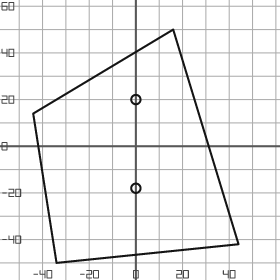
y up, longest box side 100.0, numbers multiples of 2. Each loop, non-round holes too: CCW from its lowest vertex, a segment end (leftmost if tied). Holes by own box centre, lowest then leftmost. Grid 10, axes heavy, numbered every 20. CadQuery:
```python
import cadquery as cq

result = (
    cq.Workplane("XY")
    .moveTo(-34.0, -50.0)
    .lineTo(44.0, -42.0)
    .lineTo(16.0, 50.0)
    .lineTo(-44.0, 14.0)
    .close()
    .moveTo(0.0, -18.0)
    .circle(2.0)
    .moveTo(0.0, 20.0)
    .circle(2.0)
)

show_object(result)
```